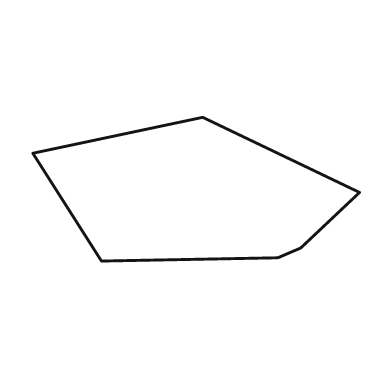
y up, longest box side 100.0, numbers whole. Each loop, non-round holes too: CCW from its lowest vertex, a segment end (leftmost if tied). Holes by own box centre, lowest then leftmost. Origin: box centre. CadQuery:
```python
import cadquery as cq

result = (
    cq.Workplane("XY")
    .moveTo(-29.0, -22.0)
    .lineTo(25.0, -21.0)
    .lineTo(32.0, -18.0)
    .lineTo(50.0, -1.0)
    .lineTo(2.0, 22.0)
    .lineTo(-50.0, 11.0)
    .close()
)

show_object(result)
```